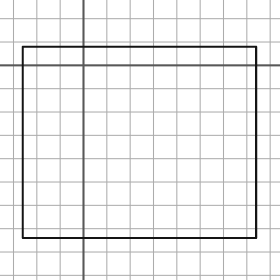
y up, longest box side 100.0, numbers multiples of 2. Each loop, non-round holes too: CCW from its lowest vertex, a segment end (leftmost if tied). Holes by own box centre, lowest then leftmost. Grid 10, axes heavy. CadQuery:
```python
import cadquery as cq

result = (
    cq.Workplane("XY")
    .moveTo(-26.0, -74.0)
    .lineTo(74.0, -74.0)
    .lineTo(74.0, 8.0)
    .lineTo(-26.0, 8.0)
    .close()
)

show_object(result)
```